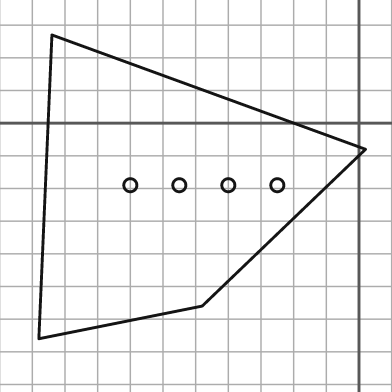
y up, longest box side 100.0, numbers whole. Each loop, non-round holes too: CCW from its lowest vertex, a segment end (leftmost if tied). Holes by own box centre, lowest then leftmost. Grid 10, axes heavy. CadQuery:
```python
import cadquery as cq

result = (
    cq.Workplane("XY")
    .moveTo(-98.0, -66.0)
    .lineTo(-48.0, -56.0)
    .lineTo(2.0, -8.0)
    .lineTo(-94.0, 27.0)
    .close()
    .moveTo(-70.0, -19.0)
    .circle(2.0)
    .moveTo(-55.0, -19.0)
    .circle(2.0)
    .moveTo(-40.0, -19.0)
    .circle(2.0)
    .moveTo(-25.0, -19.0)
    .circle(2.0)
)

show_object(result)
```